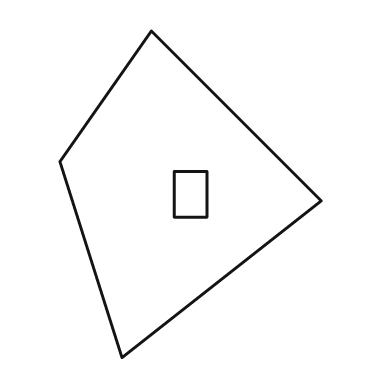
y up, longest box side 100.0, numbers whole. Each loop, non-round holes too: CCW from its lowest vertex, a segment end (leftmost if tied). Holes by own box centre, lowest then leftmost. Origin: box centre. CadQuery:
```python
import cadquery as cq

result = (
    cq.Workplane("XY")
    .moveTo(-21.0, -50.0)
    .lineTo(40.0, -2.0)
    .lineTo(-12.0, 50.0)
    .lineTo(-40.0, 10.0)
    .close()
    .moveTo(-5.0, -7.0)
    .lineTo(5.0, -7.0)
    .lineTo(5.0, 7.0)
    .lineTo(-5.0, 7.0)
    .close()
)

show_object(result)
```